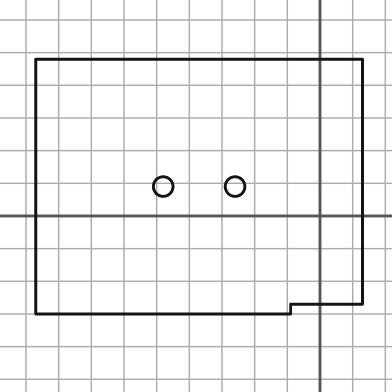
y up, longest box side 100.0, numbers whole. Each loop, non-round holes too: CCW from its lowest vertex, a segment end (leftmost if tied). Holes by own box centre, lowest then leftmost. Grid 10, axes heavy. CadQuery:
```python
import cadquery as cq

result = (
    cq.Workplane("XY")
    .moveTo(-87.0, -30.0)
    .lineTo(-9.0, -30.0)
    .lineTo(-9.0, -27.0)
    .lineTo(13.0, -27.0)
    .lineTo(13.0, 48.0)
    .lineTo(-87.0, 48.0)
    .close()
    .moveTo(-48.0, 9.0)
    .circle(3.0)
    .moveTo(-26.0, 9.0)
    .circle(3.0)
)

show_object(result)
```